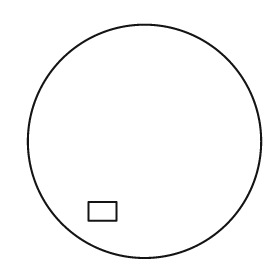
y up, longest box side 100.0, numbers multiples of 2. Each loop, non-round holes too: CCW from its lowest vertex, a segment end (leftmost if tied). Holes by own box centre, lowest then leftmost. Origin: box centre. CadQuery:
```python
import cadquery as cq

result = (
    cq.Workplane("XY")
    .moveTo(0.0, 0.0)
    .circle(50.0)
    .moveTo(-24.0, -34.0)
    .lineTo(-12.0, -34.0)
    .lineTo(-12.0, -26.0)
    .lineTo(-24.0, -26.0)
    .close()
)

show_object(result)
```